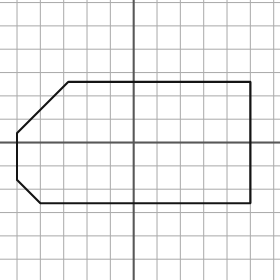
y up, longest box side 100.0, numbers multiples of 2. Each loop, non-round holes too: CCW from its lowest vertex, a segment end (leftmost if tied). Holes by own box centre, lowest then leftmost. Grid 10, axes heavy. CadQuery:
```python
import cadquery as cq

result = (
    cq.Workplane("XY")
    .moveTo(-40.0, -26.0)
    .lineTo(50.0, -26.0)
    .lineTo(50.0, 26.0)
    .lineTo(-28.0, 26.0)
    .lineTo(-50.0, 4.0)
    .lineTo(-50.0, -16.0)
    .close()
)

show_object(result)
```